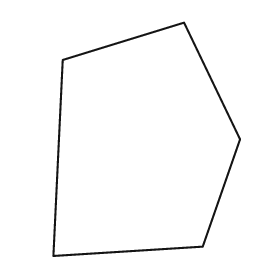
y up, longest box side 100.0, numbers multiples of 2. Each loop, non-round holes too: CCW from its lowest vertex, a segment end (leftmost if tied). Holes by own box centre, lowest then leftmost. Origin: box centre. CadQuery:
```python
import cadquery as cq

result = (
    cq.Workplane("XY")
    .moveTo(-40.0, -50.0)
    .lineTo(24.0, -46.0)
    .lineTo(40.0, 0.0)
    .lineTo(16.0, 50.0)
    .lineTo(-36.0, 34.0)
    .close()
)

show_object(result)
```